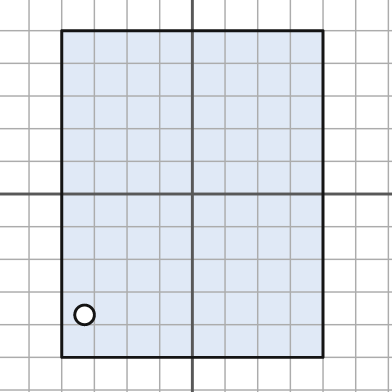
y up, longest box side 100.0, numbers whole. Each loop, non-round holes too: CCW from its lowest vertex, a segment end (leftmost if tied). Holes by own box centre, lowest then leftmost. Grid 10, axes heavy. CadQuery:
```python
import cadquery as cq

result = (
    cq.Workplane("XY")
    .moveTo(-40.0, -50.0)
    .lineTo(40.0, -50.0)
    .lineTo(40.0, 50.0)
    .lineTo(-40.0, 50.0)
    .close()
    .moveTo(-33.0, -37.0)
    .circle(3.0)
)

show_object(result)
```